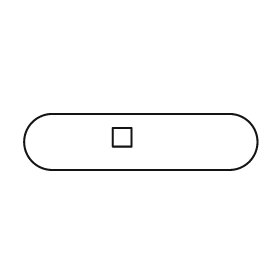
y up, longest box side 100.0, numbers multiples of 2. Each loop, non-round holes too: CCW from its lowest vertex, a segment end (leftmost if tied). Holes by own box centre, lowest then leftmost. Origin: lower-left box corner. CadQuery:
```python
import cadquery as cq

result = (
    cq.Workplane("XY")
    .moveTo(12.0, 0.0)
    .lineTo(88.0, 0.0)
    .threePointArc((100.0, 12.0), (88.0, 24.0))
    .lineTo(12.0, 24.0)
    .threePointArc((0.0, 12.0), (12.0, 0.0))
    .close()
    .moveTo(38.0, 10.0)
    .lineTo(46.0, 10.0)
    .lineTo(46.0, 18.0)
    .lineTo(38.0, 18.0)
    .close()
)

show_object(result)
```